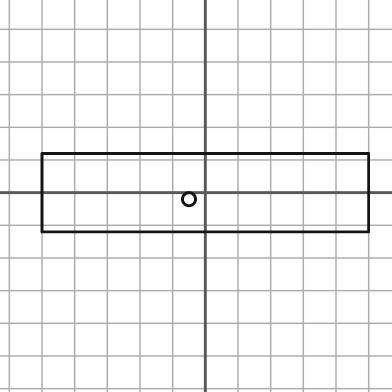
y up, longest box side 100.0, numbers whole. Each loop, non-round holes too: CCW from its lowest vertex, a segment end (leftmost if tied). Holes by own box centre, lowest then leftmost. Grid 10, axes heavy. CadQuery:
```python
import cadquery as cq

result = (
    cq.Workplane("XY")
    .moveTo(-50.0, -12.0)
    .lineTo(50.0, -12.0)
    .lineTo(50.0, 12.0)
    .lineTo(-50.0, 12.0)
    .close()
    .moveTo(-5.0, -2.0)
    .circle(2.0)
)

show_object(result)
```